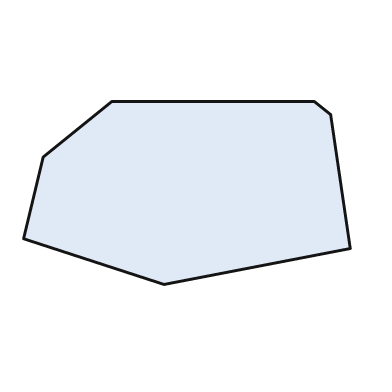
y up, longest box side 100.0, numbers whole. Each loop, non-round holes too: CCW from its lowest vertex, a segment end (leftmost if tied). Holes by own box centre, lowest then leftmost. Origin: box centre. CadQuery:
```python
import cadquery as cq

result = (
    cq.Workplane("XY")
    .moveTo(-7.0, -28.0)
    .lineTo(50.0, -17.0)
    .lineTo(44.0, 24.0)
    .lineTo(39.0, 28.0)
    .lineTo(-23.0, 28.0)
    .lineTo(-44.0, 11.0)
    .lineTo(-50.0, -14.0)
    .close()
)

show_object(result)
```